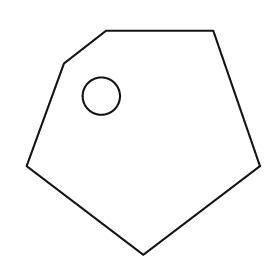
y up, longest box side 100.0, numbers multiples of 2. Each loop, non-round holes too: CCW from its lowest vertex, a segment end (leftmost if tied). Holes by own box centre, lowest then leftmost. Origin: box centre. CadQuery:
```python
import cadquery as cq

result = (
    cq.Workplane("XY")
    .moveTo(0.0, -48.0)
    .lineTo(50.0, -10.0)
    .lineTo(30.0, 48.0)
    .lineTo(-16.0, 48.0)
    .lineTo(-34.0, 34.0)
    .lineTo(-50.0, -10.0)
    .close()
    .moveTo(-18.0, 20.0)
    .circle(8.0)
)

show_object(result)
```